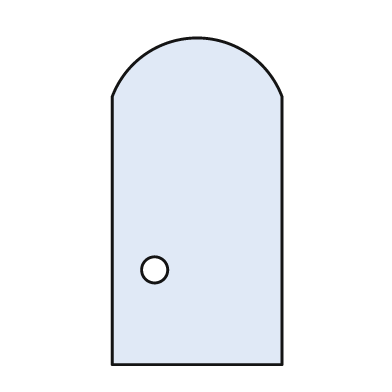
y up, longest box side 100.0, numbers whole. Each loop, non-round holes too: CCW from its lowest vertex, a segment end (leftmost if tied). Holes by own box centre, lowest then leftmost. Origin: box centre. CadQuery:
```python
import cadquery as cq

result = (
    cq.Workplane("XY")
    .moveTo(-26.0, -50.0)
    .lineTo(26.0, -50.0)
    .lineTo(26.0, 32.0)
    .threePointArc((0.0, 50.0), (-26.0, 32.0))
    .close()
    .moveTo(-13.0, -21.0)
    .circle(4.0)
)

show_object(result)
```